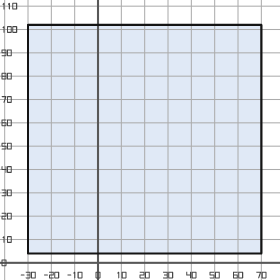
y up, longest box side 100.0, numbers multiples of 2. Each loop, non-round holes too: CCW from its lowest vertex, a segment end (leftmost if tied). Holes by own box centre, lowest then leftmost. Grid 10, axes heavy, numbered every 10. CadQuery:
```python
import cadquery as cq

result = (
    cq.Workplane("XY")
    .moveTo(-30.0, 4.0)
    .lineTo(70.0, 4.0)
    .lineTo(70.0, 102.0)
    .lineTo(-30.0, 102.0)
    .close()
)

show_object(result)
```